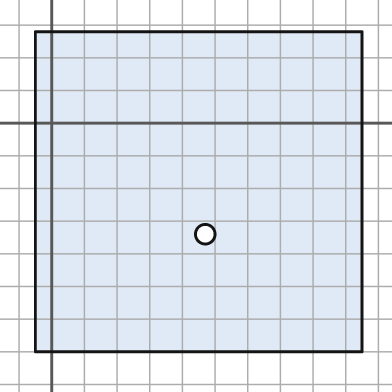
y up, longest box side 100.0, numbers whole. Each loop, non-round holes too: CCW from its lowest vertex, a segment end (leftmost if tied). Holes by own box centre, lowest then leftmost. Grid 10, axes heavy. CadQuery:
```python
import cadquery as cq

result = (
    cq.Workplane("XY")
    .moveTo(-5.0, -70.0)
    .lineTo(95.0, -70.0)
    .lineTo(95.0, 28.0)
    .lineTo(-5.0, 28.0)
    .close()
    .moveTo(47.0, -34.0)
    .circle(3.0)
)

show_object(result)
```